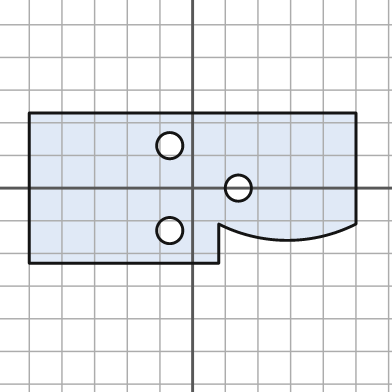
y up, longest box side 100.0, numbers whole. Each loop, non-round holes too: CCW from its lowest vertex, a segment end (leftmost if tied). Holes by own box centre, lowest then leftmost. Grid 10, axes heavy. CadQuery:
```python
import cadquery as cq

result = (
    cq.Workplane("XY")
    .moveTo(-50.0, -23.0)
    .lineTo(8.0, -23.0)
    .lineTo(8.0, -11.0)
    .threePointArc((29.0, -16.0), (50.0, -11.0))
    .lineTo(50.0, 23.0)
    .lineTo(-50.0, 23.0)
    .close()
    .moveTo(-7.0, -13.0)
    .circle(4.0)
    .moveTo(14.0, 0.0)
    .circle(4.0)
    .moveTo(-7.0, 13.0)
    .circle(4.0)
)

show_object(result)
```